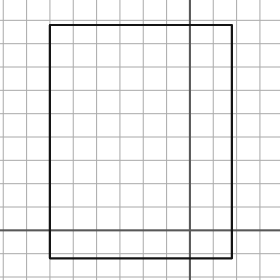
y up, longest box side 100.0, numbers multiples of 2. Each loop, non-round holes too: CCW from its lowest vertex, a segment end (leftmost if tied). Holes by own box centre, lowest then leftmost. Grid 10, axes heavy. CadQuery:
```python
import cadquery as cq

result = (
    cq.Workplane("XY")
    .moveTo(-60.0, -12.0)
    .lineTo(18.0, -12.0)
    .lineTo(18.0, 88.0)
    .lineTo(-60.0, 88.0)
    .close()
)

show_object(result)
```